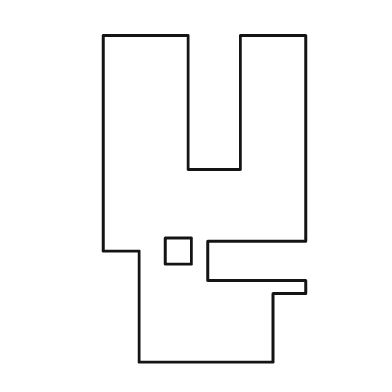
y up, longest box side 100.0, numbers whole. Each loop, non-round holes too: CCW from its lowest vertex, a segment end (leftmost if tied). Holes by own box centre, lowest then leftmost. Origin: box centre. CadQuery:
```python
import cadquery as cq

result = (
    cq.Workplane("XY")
    .moveTo(-20.0, -50.0)
    .lineTo(21.0, -50.0)
    .lineTo(21.0, -29.0)
    .lineTo(31.0, -29.0)
    .lineTo(31.0, -25.0)
    .lineTo(1.0, -25.0)
    .lineTo(1.0, -13.0)
    .lineTo(31.0, -13.0)
    .lineTo(31.0, 50.0)
    .lineTo(11.0, 50.0)
    .lineTo(11.0, 9.0)
    .lineTo(-5.0, 9.0)
    .lineTo(-5.0, 50.0)
    .lineTo(-31.0, 50.0)
    .lineTo(-31.0, -16.0)
    .lineTo(-20.0, -16.0)
    .close()
    .moveTo(-12.0, -20.0)
    .lineTo(-4.0, -20.0)
    .lineTo(-4.0, -12.0)
    .lineTo(-12.0, -12.0)
    .close()
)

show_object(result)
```